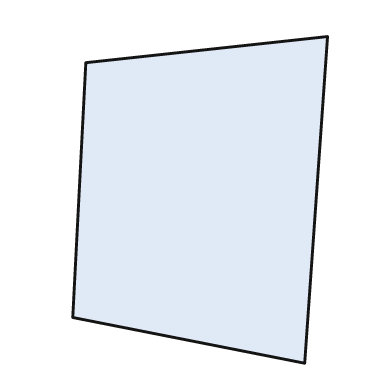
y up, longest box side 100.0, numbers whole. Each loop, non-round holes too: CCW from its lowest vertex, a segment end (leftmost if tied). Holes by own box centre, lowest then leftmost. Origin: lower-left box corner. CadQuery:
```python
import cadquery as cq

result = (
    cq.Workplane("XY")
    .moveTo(71.0, 0.0)
    .lineTo(78.0, 100.0)
    .lineTo(4.0, 92.0)
    .lineTo(0.0, 14.0)
    .close()
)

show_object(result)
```